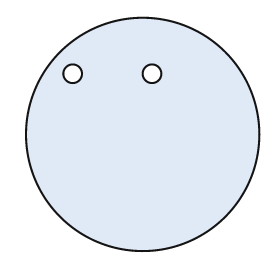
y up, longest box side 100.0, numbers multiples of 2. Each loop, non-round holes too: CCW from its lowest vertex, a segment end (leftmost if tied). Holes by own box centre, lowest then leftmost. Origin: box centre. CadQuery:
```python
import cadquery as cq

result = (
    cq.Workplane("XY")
    .moveTo(0.0, 0.0)
    .circle(50.0)
    .moveTo(-30.0, 26.0)
    .circle(4.0)
    .moveTo(4.0, 26.0)
    .circle(4.0)
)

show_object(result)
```